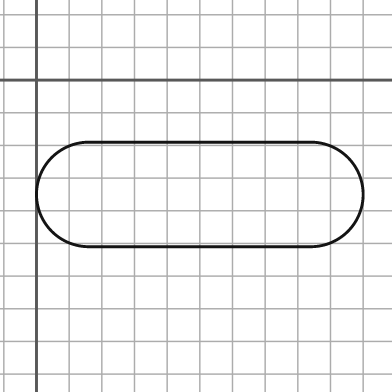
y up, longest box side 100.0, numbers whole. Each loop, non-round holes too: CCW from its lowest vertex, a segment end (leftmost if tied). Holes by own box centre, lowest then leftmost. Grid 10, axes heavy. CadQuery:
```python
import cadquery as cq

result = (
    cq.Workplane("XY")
    .moveTo(16.0, -51.0)
    .lineTo(84.0, -51.0)
    .threePointArc((100.0, -35.0), (84.0, -19.0))
    .lineTo(16.0, -19.0)
    .threePointArc((0.0, -35.0), (16.0, -51.0))
    .close()
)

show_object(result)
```